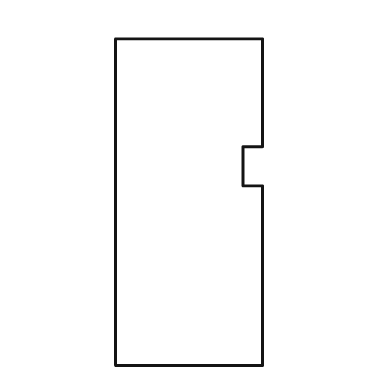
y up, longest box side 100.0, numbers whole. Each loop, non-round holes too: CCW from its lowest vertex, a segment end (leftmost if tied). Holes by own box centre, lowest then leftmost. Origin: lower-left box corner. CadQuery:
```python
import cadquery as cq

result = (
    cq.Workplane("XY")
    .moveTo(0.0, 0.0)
    .lineTo(45.0, 0.0)
    .lineTo(45.0, 55.0)
    .lineTo(39.0, 55.0)
    .lineTo(39.0, 67.0)
    .lineTo(45.0, 67.0)
    .lineTo(45.0, 100.0)
    .lineTo(0.0, 100.0)
    .close()
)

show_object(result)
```